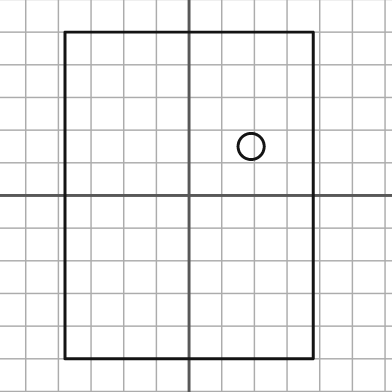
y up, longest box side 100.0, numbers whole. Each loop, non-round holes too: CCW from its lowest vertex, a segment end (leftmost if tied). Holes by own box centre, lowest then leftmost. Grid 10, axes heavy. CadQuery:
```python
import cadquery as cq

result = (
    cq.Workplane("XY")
    .moveTo(-38.0, -50.0)
    .lineTo(38.0, -50.0)
    .lineTo(38.0, 50.0)
    .lineTo(-38.0, 50.0)
    .close()
    .moveTo(19.0, 15.0)
    .circle(4.0)
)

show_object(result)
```